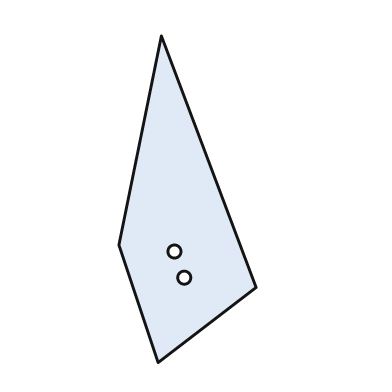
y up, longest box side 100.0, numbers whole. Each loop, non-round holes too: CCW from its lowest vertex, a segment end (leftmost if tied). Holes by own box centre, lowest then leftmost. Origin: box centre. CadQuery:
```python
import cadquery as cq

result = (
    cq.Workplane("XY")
    .moveTo(-9.0, -50.0)
    .lineTo(21.0, -27.0)
    .lineTo(-8.0, 50.0)
    .lineTo(-21.0, -14.0)
    .close()
    .moveTo(-1.0, -24.0)
    .circle(2.0)
    .moveTo(-4.0, -16.0)
    .circle(2.0)
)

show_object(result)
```